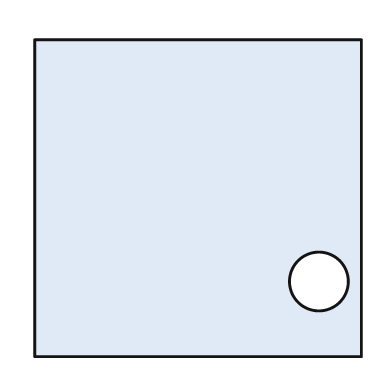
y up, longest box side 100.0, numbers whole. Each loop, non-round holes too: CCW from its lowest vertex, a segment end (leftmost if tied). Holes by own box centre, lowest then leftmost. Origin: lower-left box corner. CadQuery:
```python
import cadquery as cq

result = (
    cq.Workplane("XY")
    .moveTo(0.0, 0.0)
    .lineTo(100.0, 0.0)
    .lineTo(100.0, 97.0)
    .lineTo(0.0, 97.0)
    .close()
    .moveTo(87.0, 23.0)
    .circle(9.0)
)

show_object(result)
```